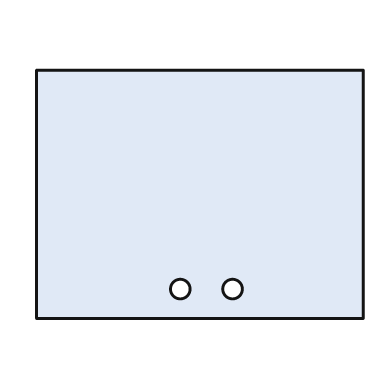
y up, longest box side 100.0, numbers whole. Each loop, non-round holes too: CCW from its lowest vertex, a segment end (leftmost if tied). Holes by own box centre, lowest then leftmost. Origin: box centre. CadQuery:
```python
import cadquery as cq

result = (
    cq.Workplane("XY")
    .moveTo(-50.0, -38.0)
    .lineTo(50.0, -38.0)
    .lineTo(50.0, 38.0)
    .lineTo(-50.0, 38.0)
    .close()
    .moveTo(-6.0, -29.0)
    .circle(3.0)
    .moveTo(10.0, -29.0)
    .circle(3.0)
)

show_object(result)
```